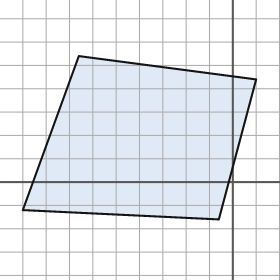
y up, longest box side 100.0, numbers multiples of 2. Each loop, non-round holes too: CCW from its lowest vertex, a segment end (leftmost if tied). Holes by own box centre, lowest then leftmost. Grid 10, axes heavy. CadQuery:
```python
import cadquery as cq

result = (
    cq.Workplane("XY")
    .moveTo(-6.0, -16.0)
    .lineTo(10.0, 44.0)
    .lineTo(-66.0, 54.0)
    .lineTo(-90.0, -12.0)
    .close()
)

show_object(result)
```